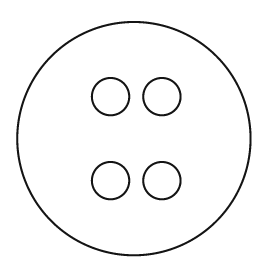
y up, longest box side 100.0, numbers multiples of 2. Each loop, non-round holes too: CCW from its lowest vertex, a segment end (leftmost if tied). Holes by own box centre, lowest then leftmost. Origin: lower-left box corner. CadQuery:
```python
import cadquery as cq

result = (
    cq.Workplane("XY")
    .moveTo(50.0, 50.0)
    .circle(50.0)
    .moveTo(40.0, 32.0)
    .circle(8.0)
    .moveTo(62.0, 32.0)
    .circle(8.0)
    .moveTo(40.0, 68.0)
    .circle(8.0)
    .moveTo(62.0, 68.0)
    .circle(8.0)
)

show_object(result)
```